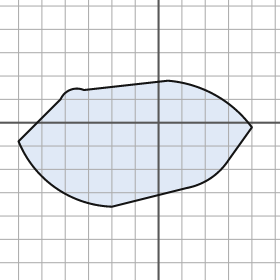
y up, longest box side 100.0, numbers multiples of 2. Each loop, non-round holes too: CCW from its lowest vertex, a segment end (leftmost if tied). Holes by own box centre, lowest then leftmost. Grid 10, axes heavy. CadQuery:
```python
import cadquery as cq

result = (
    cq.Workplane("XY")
    .moveTo(-20.0, -36.0)
    .lineTo(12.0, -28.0)
    .threePointArc((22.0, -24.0), (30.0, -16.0))
    .lineTo(40.0, -2.0)
    .threePointArc((24.0, 12.0), (4.0, 18.0))
    .lineTo(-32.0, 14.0)
    .threePointArc((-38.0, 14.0), (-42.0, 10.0))
    .lineTo(-60.0, -8.0)
    .threePointArc((-44.0, -28.0), (-20.0, -36.0))
    .close()
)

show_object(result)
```